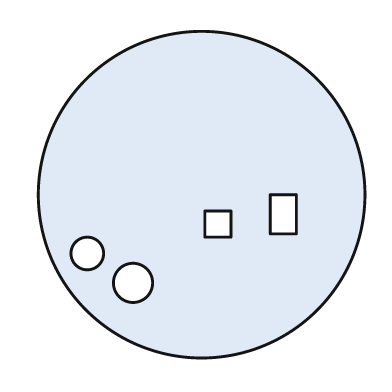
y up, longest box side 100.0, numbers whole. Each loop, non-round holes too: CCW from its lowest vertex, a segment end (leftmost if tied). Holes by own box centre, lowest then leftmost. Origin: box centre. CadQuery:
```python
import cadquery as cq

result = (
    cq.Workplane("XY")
    .moveTo(0.0, 0.0)
    .circle(50.0)
    .moveTo(-21.0, -27.0)
    .circle(6.0)
    .moveTo(-35.0, -18.0)
    .circle(5.0)
    .moveTo(1.0, -13.0)
    .lineTo(9.0, -13.0)
    .lineTo(9.0, -5.0)
    .lineTo(1.0, -5.0)
    .close()
    .moveTo(21.0, -12.0)
    .lineTo(29.0, -12.0)
    .lineTo(29.0, 0.0)
    .lineTo(21.0, 0.0)
    .close()
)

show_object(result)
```